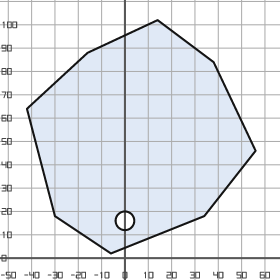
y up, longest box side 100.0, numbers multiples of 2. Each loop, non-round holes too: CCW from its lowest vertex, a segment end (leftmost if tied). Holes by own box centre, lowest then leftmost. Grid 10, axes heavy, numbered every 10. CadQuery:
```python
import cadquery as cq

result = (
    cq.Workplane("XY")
    .moveTo(-6.0, 2.0)
    .lineTo(34.0, 18.0)
    .lineTo(56.0, 46.0)
    .lineTo(38.0, 84.0)
    .lineTo(14.0, 102.0)
    .lineTo(-16.0, 88.0)
    .lineTo(-42.0, 64.0)
    .lineTo(-30.0, 18.0)
    .close()
    .moveTo(0.0, 16.0)
    .circle(4.0)
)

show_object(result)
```